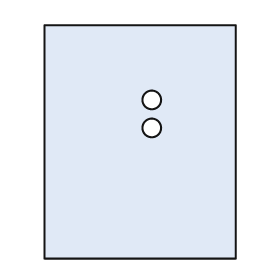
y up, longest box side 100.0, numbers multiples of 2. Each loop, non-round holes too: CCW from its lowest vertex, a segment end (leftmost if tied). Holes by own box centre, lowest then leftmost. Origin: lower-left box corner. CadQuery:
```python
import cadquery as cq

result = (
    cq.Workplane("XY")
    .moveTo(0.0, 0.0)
    .lineTo(82.0, 0.0)
    .lineTo(82.0, 100.0)
    .lineTo(0.0, 100.0)
    .close()
    .moveTo(46.0, 56.0)
    .circle(4.0)
    .moveTo(46.0, 68.0)
    .circle(4.0)
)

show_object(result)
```